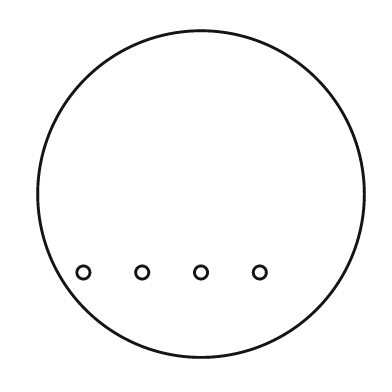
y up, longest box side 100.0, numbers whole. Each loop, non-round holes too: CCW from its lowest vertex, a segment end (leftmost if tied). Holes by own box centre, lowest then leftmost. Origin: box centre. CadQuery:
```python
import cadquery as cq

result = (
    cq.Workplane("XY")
    .moveTo(0.0, 0.0)
    .circle(50.0)
    .moveTo(-36.0, -24.0)
    .circle(2.0)
    .moveTo(-18.0, -24.0)
    .circle(2.0)
    .moveTo(0.0, -24.0)
    .circle(2.0)
    .moveTo(18.0, -24.0)
    .circle(2.0)
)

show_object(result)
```